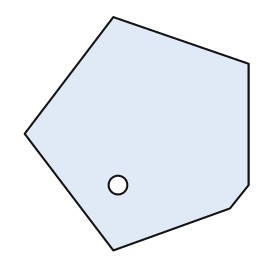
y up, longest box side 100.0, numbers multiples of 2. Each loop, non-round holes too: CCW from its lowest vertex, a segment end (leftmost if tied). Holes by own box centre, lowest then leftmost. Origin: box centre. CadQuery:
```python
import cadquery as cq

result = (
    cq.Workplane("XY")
    .moveTo(-10.0, -50.0)
    .lineTo(40.0, -32.0)
    .lineTo(48.0, -22.0)
    .lineTo(48.0, 30.0)
    .lineTo(-10.0, 50.0)
    .lineTo(-48.0, 0.0)
    .close()
    .moveTo(-8.0, -22.0)
    .circle(4.0)
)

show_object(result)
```